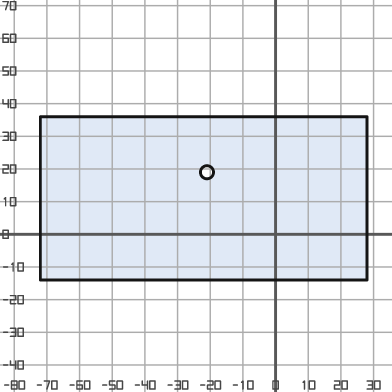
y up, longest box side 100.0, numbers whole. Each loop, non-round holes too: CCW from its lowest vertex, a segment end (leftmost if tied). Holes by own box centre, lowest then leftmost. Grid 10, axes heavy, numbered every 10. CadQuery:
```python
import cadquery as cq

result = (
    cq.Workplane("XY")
    .moveTo(-72.0, -14.0)
    .lineTo(28.0, -14.0)
    .lineTo(28.0, 36.0)
    .lineTo(-72.0, 36.0)
    .close()
    .moveTo(-21.0, 19.0)
    .circle(2.0)
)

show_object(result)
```